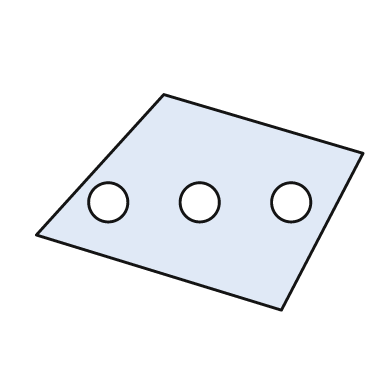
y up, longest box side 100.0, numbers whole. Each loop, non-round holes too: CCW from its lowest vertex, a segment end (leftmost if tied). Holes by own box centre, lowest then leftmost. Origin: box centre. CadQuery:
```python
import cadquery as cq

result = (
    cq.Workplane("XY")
    .moveTo(25.0, -33.0)
    .lineTo(50.0, 15.0)
    .lineTo(-11.0, 33.0)
    .lineTo(-50.0, -10.0)
    .close()
    .moveTo(-28.0, 0.0)
    .circle(6.0)
    .moveTo(0.0, 0.0)
    .circle(6.0)
    .moveTo(28.0, 0.0)
    .circle(6.0)
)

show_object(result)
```